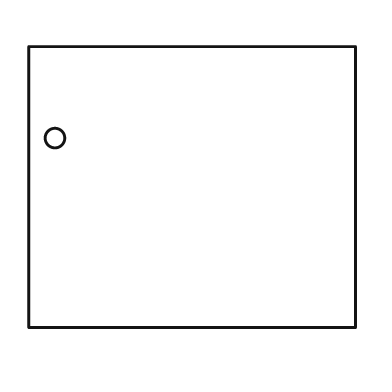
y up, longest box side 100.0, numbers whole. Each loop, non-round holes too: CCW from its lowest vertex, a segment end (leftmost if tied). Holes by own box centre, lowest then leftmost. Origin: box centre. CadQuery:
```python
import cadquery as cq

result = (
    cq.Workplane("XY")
    .moveTo(-50.0, -43.0)
    .lineTo(50.0, -43.0)
    .lineTo(50.0, 43.0)
    .lineTo(-50.0, 43.0)
    .close()
    .moveTo(-42.0, 15.0)
    .circle(3.0)
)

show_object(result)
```